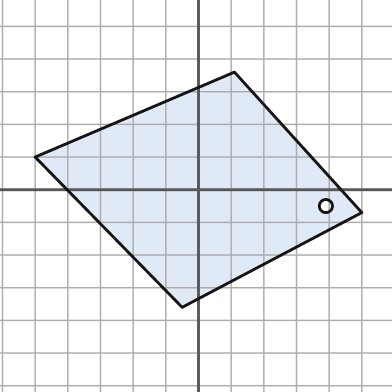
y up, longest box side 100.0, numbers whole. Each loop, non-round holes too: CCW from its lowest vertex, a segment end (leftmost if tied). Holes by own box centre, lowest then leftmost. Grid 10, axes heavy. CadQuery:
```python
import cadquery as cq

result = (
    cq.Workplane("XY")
    .moveTo(-5.0, -36.0)
    .lineTo(50.0, -7.0)
    .lineTo(11.0, 36.0)
    .lineTo(-50.0, 10.0)
    .close()
    .moveTo(39.0, -5.0)
    .circle(2.0)
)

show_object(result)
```